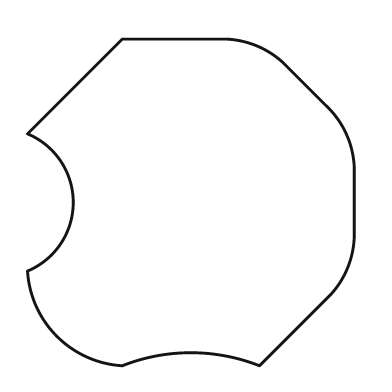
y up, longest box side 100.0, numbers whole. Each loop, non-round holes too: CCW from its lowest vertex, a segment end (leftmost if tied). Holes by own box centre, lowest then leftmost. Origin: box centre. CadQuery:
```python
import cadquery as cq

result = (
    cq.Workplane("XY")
    .moveTo(-21.0, -50.0)
    .threePointArc((0.0, -46.0), (21.0, -50.0))
    .lineTo(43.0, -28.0)
    .threePointArc((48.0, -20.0), (50.0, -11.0))
    .lineTo(50.0, 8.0)
    .threePointArc((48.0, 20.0), (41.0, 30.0))
    .lineTo(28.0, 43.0)
    .threePointArc((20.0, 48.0), (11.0, 50.0))
    .lineTo(-21.0, 50.0)
    .lineTo(-50.0, 21.0)
    .threePointArc((-36.0, 0.0), (-50.0, -21.0))
    .threePointArc((-41.0, -41.0), (-21.0, -50.0))
    .close()
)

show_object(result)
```